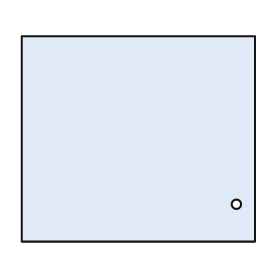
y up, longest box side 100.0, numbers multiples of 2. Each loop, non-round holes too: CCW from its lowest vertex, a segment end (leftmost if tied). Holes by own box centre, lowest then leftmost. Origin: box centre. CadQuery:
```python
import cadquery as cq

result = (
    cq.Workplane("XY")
    .moveTo(-50.0, -44.0)
    .lineTo(50.0, -44.0)
    .lineTo(50.0, 44.0)
    .lineTo(-50.0, 44.0)
    .close()
    .moveTo(42.0, -28.0)
    .circle(2.0)
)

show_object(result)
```